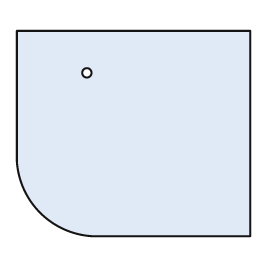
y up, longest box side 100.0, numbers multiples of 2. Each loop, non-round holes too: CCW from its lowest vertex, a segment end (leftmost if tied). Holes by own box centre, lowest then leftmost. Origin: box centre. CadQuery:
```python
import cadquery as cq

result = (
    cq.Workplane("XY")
    .moveTo(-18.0, -44.0)
    .lineTo(50.0, -44.0)
    .lineTo(50.0, 44.0)
    .lineTo(-50.0, 44.0)
    .lineTo(-50.0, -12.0)
    .threePointArc((-40.0, -34.0), (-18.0, -44.0))
    .close()
    .moveTo(-20.0, 26.0)
    .circle(2.0)
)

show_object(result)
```